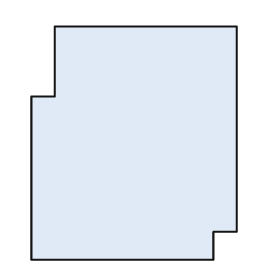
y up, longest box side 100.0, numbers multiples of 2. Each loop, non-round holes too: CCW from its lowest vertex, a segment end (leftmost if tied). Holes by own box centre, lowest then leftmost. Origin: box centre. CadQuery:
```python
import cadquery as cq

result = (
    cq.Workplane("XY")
    .moveTo(-44.0, -50.0)
    .lineTo(34.0, -50.0)
    .lineTo(34.0, -38.0)
    .lineTo(44.0, -38.0)
    .lineTo(44.0, 50.0)
    .lineTo(-34.0, 50.0)
    .lineTo(-34.0, 20.0)
    .lineTo(-44.0, 20.0)
    .close()
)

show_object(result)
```